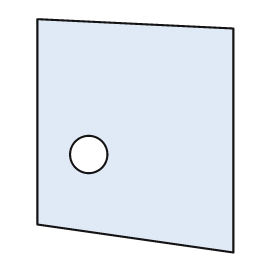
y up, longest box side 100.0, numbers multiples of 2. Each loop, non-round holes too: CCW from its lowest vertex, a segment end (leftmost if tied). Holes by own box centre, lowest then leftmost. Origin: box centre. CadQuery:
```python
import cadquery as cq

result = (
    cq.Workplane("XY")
    .moveTo(42.0, -50.0)
    .lineTo(42.0, 46.0)
    .lineTo(-42.0, 50.0)
    .lineTo(-42.0, -38.0)
    .close()
    .moveTo(-20.0, -8.0)
    .circle(8.0)
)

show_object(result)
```